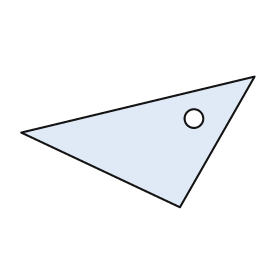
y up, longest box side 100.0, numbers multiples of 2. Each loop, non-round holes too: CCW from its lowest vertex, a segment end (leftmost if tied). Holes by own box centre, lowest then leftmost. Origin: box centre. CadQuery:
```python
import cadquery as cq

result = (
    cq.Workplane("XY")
    .moveTo(18.0, -28.0)
    .lineTo(50.0, 28.0)
    .lineTo(-50.0, 4.0)
    .close()
    .moveTo(24.0, 10.0)
    .circle(4.0)
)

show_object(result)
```